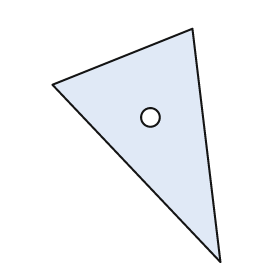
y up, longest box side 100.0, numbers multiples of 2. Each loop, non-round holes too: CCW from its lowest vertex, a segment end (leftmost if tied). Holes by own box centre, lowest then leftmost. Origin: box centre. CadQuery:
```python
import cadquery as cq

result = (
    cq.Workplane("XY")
    .moveTo(36.0, -50.0)
    .lineTo(24.0, 50.0)
    .lineTo(-36.0, 26.0)
    .close()
    .moveTo(6.0, 12.0)
    .circle(4.0)
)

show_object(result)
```